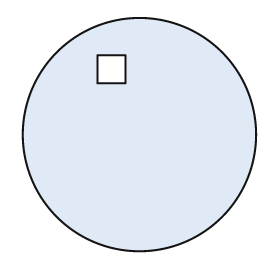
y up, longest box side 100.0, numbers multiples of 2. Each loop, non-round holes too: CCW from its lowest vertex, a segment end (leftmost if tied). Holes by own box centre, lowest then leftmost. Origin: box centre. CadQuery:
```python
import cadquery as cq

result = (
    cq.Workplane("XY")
    .moveTo(0.0, 0.0)
    .circle(50.0)
    .moveTo(-18.0, 22.0)
    .lineTo(-6.0, 22.0)
    .lineTo(-6.0, 34.0)
    .lineTo(-18.0, 34.0)
    .close()
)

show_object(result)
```